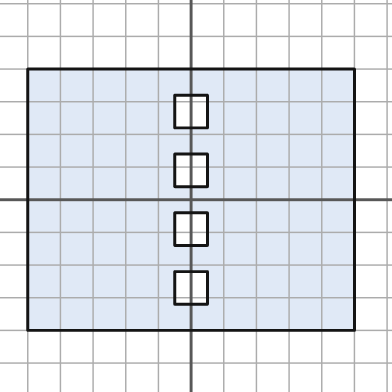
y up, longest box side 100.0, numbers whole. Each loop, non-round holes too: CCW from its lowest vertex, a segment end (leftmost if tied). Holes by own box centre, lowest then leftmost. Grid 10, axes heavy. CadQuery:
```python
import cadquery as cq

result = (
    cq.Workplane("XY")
    .moveTo(-50.0, -40.0)
    .lineTo(50.0, -40.0)
    .lineTo(50.0, 40.0)
    .lineTo(-50.0, 40.0)
    .close()
    .moveTo(-5.0, -32.0)
    .lineTo(5.0, -32.0)
    .lineTo(5.0, -22.0)
    .lineTo(-5.0, -22.0)
    .close()
    .moveTo(-5.0, -14.0)
    .lineTo(5.0, -14.0)
    .lineTo(5.0, -4.0)
    .lineTo(-5.0, -4.0)
    .close()
    .moveTo(-5.0, 4.0)
    .lineTo(5.0, 4.0)
    .lineTo(5.0, 14.0)
    .lineTo(-5.0, 14.0)
    .close()
    .moveTo(-5.0, 22.0)
    .lineTo(5.0, 22.0)
    .lineTo(5.0, 32.0)
    .lineTo(-5.0, 32.0)
    .close()
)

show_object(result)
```